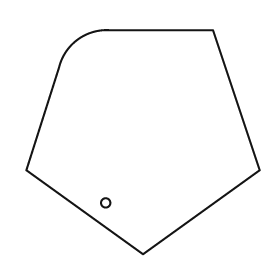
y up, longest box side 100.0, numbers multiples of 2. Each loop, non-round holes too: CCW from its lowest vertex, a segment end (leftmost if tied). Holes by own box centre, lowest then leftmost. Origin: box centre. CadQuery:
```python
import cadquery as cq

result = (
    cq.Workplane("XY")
    .moveTo(0.0, -48.0)
    .lineTo(50.0, -12.0)
    .lineTo(30.0, 48.0)
    .lineTo(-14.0, 48.0)
    .threePointArc((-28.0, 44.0), (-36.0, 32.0))
    .lineTo(-50.0, -12.0)
    .close()
    .moveTo(-16.0, -26.0)
    .circle(2.0)
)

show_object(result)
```